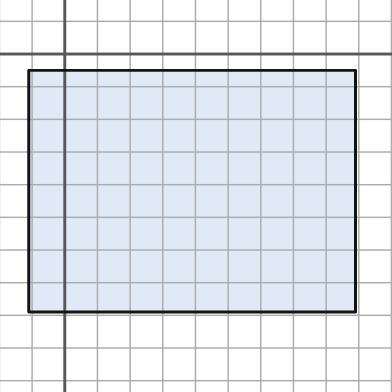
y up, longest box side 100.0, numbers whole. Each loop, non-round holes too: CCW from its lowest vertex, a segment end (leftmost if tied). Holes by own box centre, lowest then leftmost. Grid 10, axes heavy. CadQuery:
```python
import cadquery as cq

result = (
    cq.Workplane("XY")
    .moveTo(-11.0, -79.0)
    .lineTo(89.0, -79.0)
    .lineTo(89.0, -5.0)
    .lineTo(-11.0, -5.0)
    .close()
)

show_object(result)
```